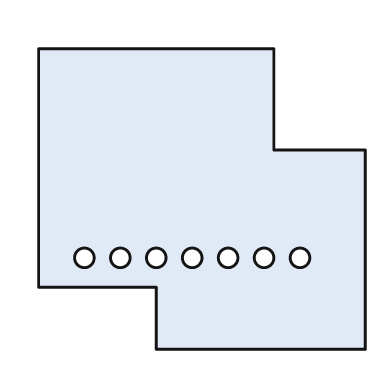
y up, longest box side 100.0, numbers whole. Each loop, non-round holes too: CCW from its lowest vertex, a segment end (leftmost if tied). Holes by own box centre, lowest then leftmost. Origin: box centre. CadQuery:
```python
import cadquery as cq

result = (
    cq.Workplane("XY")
    .moveTo(-14.0, -46.0)
    .lineTo(50.0, -46.0)
    .lineTo(50.0, 15.0)
    .lineTo(22.0, 15.0)
    .lineTo(22.0, 46.0)
    .lineTo(-50.0, 46.0)
    .lineTo(-50.0, -27.0)
    .lineTo(-14.0, -27.0)
    .close()
    .moveTo(-36.0, -18.0)
    .circle(3.0)
    .moveTo(-25.0, -18.0)
    .circle(3.0)
    .moveTo(-14.0, -18.0)
    .circle(3.0)
    .moveTo(-3.0, -18.0)
    .circle(3.0)
    .moveTo(8.0, -18.0)
    .circle(3.0)
    .moveTo(19.0, -18.0)
    .circle(3.0)
    .moveTo(30.0, -18.0)
    .circle(3.0)
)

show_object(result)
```